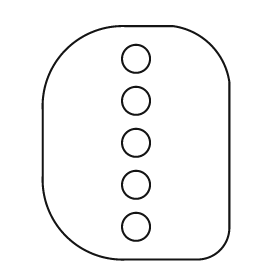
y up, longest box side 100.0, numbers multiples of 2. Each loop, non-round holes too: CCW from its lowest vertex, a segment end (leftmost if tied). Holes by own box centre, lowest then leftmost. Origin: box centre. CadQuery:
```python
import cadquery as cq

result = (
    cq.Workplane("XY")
    .moveTo(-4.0, -50.0)
    .lineTo(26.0, -50.0)
    .threePointArc((36.0, -46.0), (40.0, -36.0))
    .lineTo(40.0, 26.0)
    .threePointArc((32.0, 42.0), (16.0, 50.0))
    .lineTo(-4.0, 50.0)
    .threePointArc((-30.0, 40.0), (-40.0, 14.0))
    .lineTo(-40.0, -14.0)
    .threePointArc((-30.0, -40.0), (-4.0, -50.0))
    .close()
    .moveTo(0.0, -36.0)
    .circle(6.0)
    .moveTo(0.0, -18.0)
    .circle(6.0)
    .moveTo(0.0, 0.0)
    .circle(6.0)
    .moveTo(0.0, 18.0)
    .circle(6.0)
    .moveTo(0.0, 36.0)
    .circle(6.0)
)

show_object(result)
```